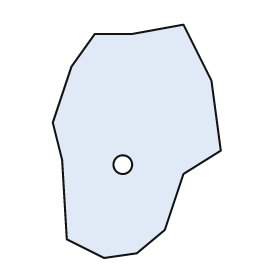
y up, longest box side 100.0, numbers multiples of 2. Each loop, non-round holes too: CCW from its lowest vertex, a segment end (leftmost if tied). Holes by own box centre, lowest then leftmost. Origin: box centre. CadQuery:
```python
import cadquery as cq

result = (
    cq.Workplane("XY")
    .moveTo(-14.0, -50.0)
    .lineTo(0.0, -48.0)
    .lineTo(12.0, -38.0)
    .lineTo(20.0, -14.0)
    .lineTo(36.0, -4.0)
    .lineTo(32.0, 26.0)
    .lineTo(20.0, 50.0)
    .lineTo(-2.0, 46.0)
    .lineTo(-18.0, 46.0)
    .lineTo(-28.0, 32.0)
    .lineTo(-36.0, 8.0)
    .lineTo(-32.0, -8.0)
    .lineTo(-30.0, -42.0)
    .close()
    .moveTo(-6.0, -10.0)
    .circle(4.0)
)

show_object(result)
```